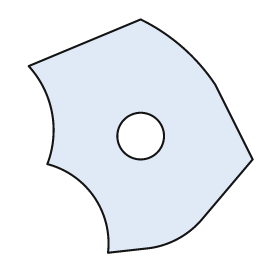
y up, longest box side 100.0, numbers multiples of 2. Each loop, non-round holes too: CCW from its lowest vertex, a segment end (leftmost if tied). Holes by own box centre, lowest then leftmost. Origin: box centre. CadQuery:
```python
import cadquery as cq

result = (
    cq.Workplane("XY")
    .moveTo(-14.0, -50.0)
    .lineTo(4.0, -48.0)
    .threePointArc((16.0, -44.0), (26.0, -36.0))
    .lineTo(48.0, -10.0)
    .lineTo(32.0, 22.0)
    .threePointArc((18.0, 38.0), (0.0, 50.0))
    .lineTo(-48.0, 30.0)
    .threePointArc((-38.0, 10.0), (-40.0, -12.0))
    .threePointArc((-20.0, -26.0), (-14.0, -50.0))
    .close()
    .moveTo(0.0, 0.0)
    .circle(10.0)
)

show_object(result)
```